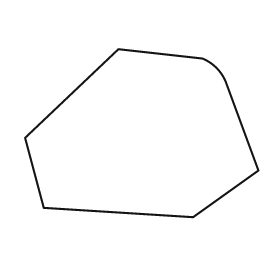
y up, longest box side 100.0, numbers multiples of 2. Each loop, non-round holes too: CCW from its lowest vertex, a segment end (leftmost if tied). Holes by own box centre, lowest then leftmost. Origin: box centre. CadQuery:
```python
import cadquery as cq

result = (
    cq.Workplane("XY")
    .moveTo(22.0, -36.0)
    .lineTo(50.0, -16.0)
    .lineTo(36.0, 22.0)
    .threePointArc((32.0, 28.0), (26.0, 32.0))
    .lineTo(-10.0, 36.0)
    .lineTo(-50.0, -2.0)
    .lineTo(-42.0, -32.0)
    .close()
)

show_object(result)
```